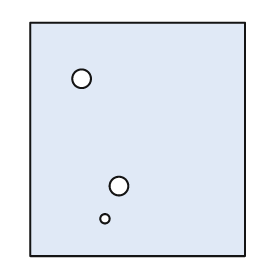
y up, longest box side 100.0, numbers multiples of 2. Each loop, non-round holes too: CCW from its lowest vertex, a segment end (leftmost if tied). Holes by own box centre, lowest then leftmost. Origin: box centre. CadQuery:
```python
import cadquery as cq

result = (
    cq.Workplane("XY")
    .moveTo(-46.0, -50.0)
    .lineTo(46.0, -50.0)
    .lineTo(46.0, 50.0)
    .lineTo(-46.0, 50.0)
    .close()
    .moveTo(-14.0, -34.0)
    .circle(2.0)
    .moveTo(-8.0, -20.0)
    .circle(4.0)
    .moveTo(-24.0, 26.0)
    .circle(4.0)
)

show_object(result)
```